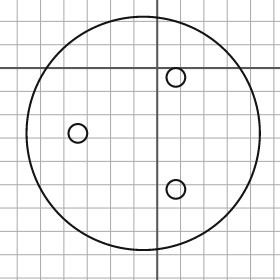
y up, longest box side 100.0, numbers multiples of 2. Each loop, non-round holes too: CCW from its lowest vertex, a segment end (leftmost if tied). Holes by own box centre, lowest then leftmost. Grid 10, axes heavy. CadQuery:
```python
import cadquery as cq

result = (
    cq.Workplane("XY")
    .moveTo(-6.0, -28.0)
    .circle(50.0)
    .moveTo(8.0, -52.0)
    .circle(4.0)
    .moveTo(-34.0, -28.0)
    .circle(4.0)
    .moveTo(8.0, -4.0)
    .circle(4.0)
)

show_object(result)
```